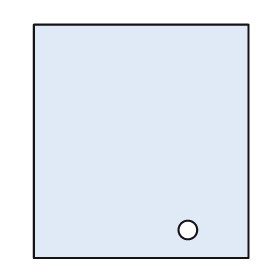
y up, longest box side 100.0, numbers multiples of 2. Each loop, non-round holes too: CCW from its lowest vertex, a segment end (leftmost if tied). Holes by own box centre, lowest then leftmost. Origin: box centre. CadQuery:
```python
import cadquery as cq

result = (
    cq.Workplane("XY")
    .moveTo(-46.0, -50.0)
    .lineTo(46.0, -50.0)
    .lineTo(46.0, 50.0)
    .lineTo(-46.0, 50.0)
    .close()
    .moveTo(20.0, -38.0)
    .circle(4.0)
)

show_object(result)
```